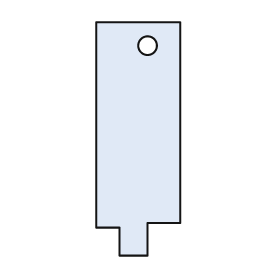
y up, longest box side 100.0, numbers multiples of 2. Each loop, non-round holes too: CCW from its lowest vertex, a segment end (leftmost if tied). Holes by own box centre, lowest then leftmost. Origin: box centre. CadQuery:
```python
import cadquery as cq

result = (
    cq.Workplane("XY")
    .moveTo(-8.0, -50.0)
    .lineTo(4.0, -50.0)
    .lineTo(4.0, -36.0)
    .lineTo(18.0, -36.0)
    .lineTo(18.0, 50.0)
    .lineTo(-18.0, 50.0)
    .lineTo(-18.0, -38.0)
    .lineTo(-8.0, -38.0)
    .close()
    .moveTo(4.0, 40.0)
    .circle(4.0)
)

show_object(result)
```